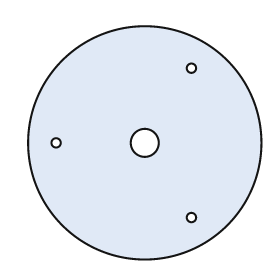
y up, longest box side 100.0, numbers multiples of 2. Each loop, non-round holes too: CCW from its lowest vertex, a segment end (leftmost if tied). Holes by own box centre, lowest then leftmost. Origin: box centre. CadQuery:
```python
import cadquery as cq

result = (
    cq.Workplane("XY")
    .moveTo(0.0, 0.0)
    .circle(50.0)
    .moveTo(20.0, -32.0)
    .circle(2.0)
    .moveTo(-38.0, 0.0)
    .circle(2.0)
    .moveTo(0.0, 0.0)
    .circle(6.0)
    .moveTo(20.0, 32.0)
    .circle(2.0)
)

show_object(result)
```